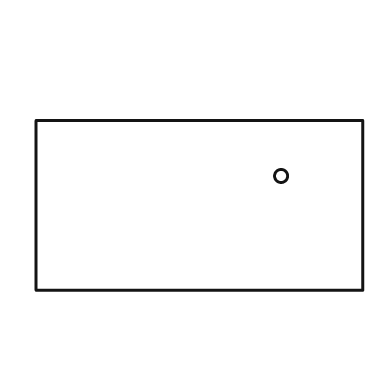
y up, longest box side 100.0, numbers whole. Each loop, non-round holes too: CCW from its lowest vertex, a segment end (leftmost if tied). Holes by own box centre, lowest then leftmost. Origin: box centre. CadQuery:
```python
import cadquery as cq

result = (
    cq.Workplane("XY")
    .moveTo(-50.0, -26.0)
    .lineTo(50.0, -26.0)
    .lineTo(50.0, 26.0)
    .lineTo(-50.0, 26.0)
    .close()
    .moveTo(25.0, 9.0)
    .circle(2.0)
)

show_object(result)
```